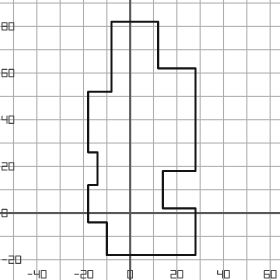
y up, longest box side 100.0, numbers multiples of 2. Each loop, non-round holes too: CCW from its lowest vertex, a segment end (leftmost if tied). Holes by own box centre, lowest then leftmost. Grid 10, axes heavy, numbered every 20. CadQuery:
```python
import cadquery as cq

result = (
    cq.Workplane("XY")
    .moveTo(-10.0, -18.0)
    .lineTo(28.0, -18.0)
    .lineTo(28.0, 2.0)
    .lineTo(14.0, 2.0)
    .lineTo(14.0, 18.0)
    .lineTo(28.0, 18.0)
    .lineTo(28.0, 62.0)
    .lineTo(12.0, 62.0)
    .lineTo(12.0, 82.0)
    .lineTo(-8.0, 82.0)
    .lineTo(-8.0, 52.0)
    .lineTo(-18.0, 52.0)
    .lineTo(-18.0, 26.0)
    .lineTo(-14.0, 26.0)
    .lineTo(-14.0, 12.0)
    .lineTo(-18.0, 12.0)
    .lineTo(-18.0, -4.0)
    .lineTo(-10.0, -4.0)
    .close()
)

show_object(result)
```